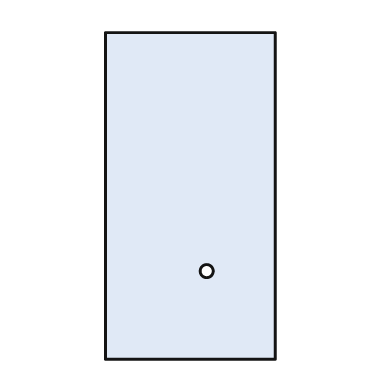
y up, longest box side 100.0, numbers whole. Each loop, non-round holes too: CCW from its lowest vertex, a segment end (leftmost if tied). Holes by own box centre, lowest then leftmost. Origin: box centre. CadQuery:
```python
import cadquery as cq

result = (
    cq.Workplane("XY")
    .moveTo(-26.0, -50.0)
    .lineTo(26.0, -50.0)
    .lineTo(26.0, 50.0)
    .lineTo(-26.0, 50.0)
    .close()
    .moveTo(5.0, -23.0)
    .circle(2.0)
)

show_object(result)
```